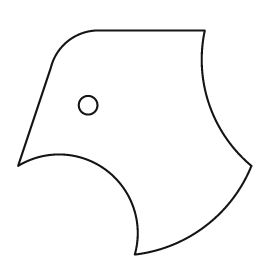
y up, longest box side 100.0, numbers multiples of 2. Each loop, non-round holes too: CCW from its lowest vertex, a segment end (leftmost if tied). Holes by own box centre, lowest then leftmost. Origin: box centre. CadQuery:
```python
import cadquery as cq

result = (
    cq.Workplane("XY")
    .moveTo(0.0, -48.0)
    .threePointArc((30.0, -36.0), (50.0, -10.0))
    .threePointArc((32.0, 16.0), (30.0, 48.0))
    .lineTo(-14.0, 48.0)
    .threePointArc((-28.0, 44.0), (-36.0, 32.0))
    .lineTo(-50.0, -10.0)
    .threePointArc((-12.0, -12.0), (0.0, -48.0))
    .close()
    .moveTo(-20.0, 16.0)
    .circle(4.0)
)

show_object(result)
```